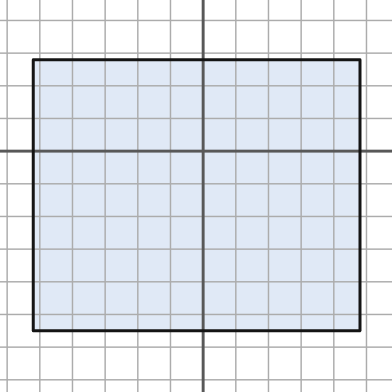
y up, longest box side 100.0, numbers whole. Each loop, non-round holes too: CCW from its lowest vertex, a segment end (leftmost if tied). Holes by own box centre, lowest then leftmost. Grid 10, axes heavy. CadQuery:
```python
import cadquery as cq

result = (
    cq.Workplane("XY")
    .moveTo(-52.0, -55.0)
    .lineTo(48.0, -55.0)
    .lineTo(48.0, 28.0)
    .lineTo(-52.0, 28.0)
    .close()
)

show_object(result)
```